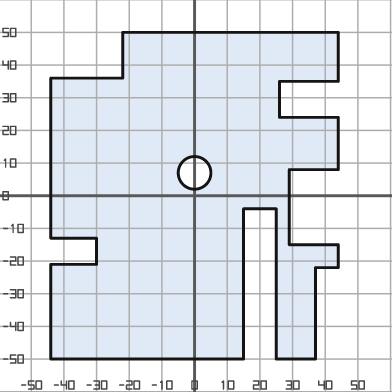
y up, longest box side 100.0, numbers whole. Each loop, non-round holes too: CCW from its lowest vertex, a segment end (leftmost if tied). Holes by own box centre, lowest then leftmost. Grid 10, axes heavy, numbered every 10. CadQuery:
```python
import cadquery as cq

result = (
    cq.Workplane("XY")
    .moveTo(-44.0, -50.0)
    .lineTo(15.0, -50.0)
    .lineTo(15.0, -4.0)
    .lineTo(25.0, -4.0)
    .lineTo(25.0, -50.0)
    .lineTo(37.0, -50.0)
    .lineTo(37.0, -22.0)
    .lineTo(44.0, -22.0)
    .lineTo(44.0, -15.0)
    .lineTo(29.0, -15.0)
    .lineTo(29.0, 8.0)
    .lineTo(44.0, 8.0)
    .lineTo(44.0, 24.0)
    .lineTo(26.0, 24.0)
    .lineTo(26.0, 35.0)
    .lineTo(44.0, 35.0)
    .lineTo(44.0, 50.0)
    .lineTo(-22.0, 50.0)
    .lineTo(-22.0, 36.0)
    .lineTo(-44.0, 36.0)
    .lineTo(-44.0, -13.0)
    .lineTo(-30.0, -13.0)
    .lineTo(-30.0, -21.0)
    .lineTo(-44.0, -21.0)
    .close()
    .moveTo(0.0, 7.0)
    .circle(5.0)
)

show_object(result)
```